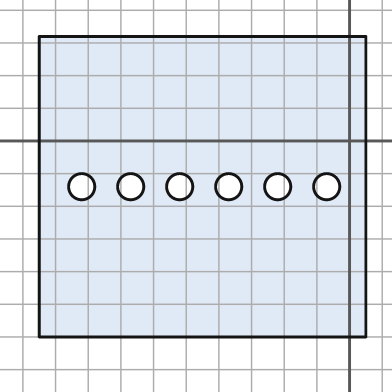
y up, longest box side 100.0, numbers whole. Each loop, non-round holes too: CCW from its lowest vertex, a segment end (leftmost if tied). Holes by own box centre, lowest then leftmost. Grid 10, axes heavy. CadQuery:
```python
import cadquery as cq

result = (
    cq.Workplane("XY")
    .moveTo(-95.0, -60.0)
    .lineTo(5.0, -60.0)
    .lineTo(5.0, 32.0)
    .lineTo(-95.0, 32.0)
    .close()
    .moveTo(-82.0, -14.0)
    .circle(4.0)
    .moveTo(-67.0, -14.0)
    .circle(4.0)
    .moveTo(-52.0, -14.0)
    .circle(4.0)
    .moveTo(-37.0, -14.0)
    .circle(4.0)
    .moveTo(-22.0, -14.0)
    .circle(4.0)
    .moveTo(-7.0, -14.0)
    .circle(4.0)
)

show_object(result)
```